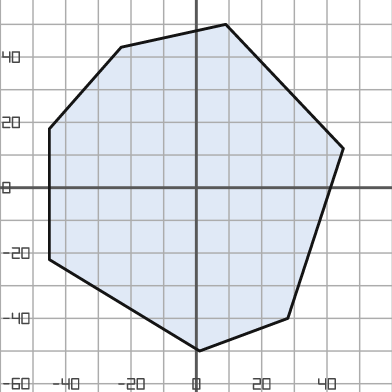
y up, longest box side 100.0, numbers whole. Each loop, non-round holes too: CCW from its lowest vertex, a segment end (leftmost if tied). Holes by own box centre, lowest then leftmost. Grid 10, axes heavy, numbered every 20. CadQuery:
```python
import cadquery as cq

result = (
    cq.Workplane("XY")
    .moveTo(1.0, -50.0)
    .lineTo(28.0, -40.0)
    .lineTo(45.0, 12.0)
    .lineTo(9.0, 50.0)
    .lineTo(-23.0, 43.0)
    .lineTo(-45.0, 18.0)
    .lineTo(-45.0, -22.0)
    .close()
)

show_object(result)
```